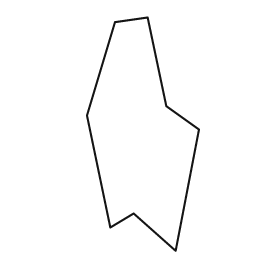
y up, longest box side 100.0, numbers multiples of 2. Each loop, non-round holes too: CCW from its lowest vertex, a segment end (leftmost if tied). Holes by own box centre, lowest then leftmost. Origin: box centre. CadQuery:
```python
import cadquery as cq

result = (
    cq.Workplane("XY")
    .moveTo(14.0, -50.0)
    .lineTo(24.0, 2.0)
    .lineTo(10.0, 12.0)
    .lineTo(2.0, 50.0)
    .lineTo(-12.0, 48.0)
    .lineTo(-24.0, 8.0)
    .lineTo(-14.0, -40.0)
    .lineTo(-4.0, -34.0)
    .close()
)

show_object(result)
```